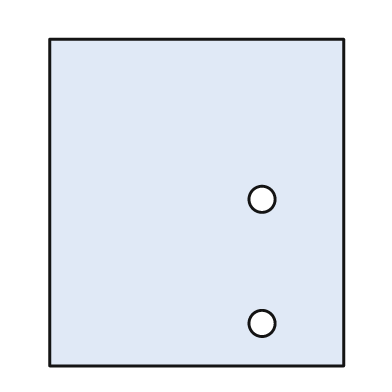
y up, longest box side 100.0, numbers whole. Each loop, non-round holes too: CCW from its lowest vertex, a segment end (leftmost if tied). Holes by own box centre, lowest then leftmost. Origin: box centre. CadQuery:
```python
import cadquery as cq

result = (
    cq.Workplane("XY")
    .moveTo(-45.0, -50.0)
    .lineTo(45.0, -50.0)
    .lineTo(45.0, 50.0)
    .lineTo(-45.0, 50.0)
    .close()
    .moveTo(20.0, -37.0)
    .circle(4.0)
    .moveTo(20.0, 1.0)
    .circle(4.0)
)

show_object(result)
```